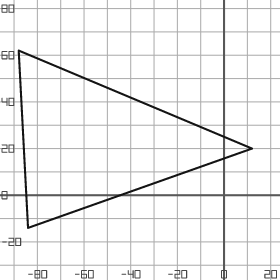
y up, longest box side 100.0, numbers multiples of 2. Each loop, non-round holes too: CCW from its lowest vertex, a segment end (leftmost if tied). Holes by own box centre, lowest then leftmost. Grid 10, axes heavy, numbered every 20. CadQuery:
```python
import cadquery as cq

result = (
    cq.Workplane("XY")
    .moveTo(-84.0, -14.0)
    .lineTo(12.0, 20.0)
    .lineTo(-88.0, 62.0)
    .close()
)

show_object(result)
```